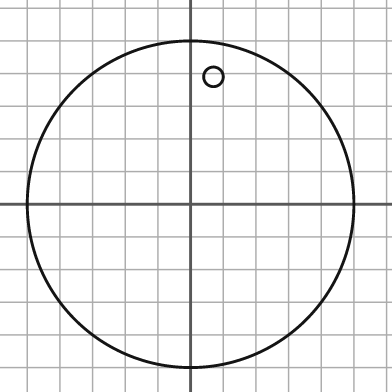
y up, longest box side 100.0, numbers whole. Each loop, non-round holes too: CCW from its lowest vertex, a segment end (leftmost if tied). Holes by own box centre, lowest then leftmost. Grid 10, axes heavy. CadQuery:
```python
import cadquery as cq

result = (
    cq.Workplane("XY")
    .moveTo(0.0, 0.0)
    .circle(50.0)
    .moveTo(7.0, 39.0)
    .circle(3.0)
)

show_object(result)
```